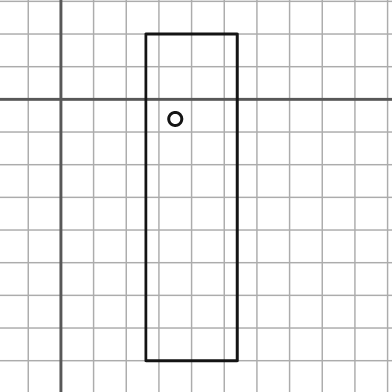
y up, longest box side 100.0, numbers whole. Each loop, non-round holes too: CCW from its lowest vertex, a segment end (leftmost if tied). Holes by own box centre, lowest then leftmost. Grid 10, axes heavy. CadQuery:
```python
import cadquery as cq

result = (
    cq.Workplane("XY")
    .moveTo(26.0, -80.0)
    .lineTo(54.0, -80.0)
    .lineTo(54.0, 20.0)
    .lineTo(26.0, 20.0)
    .close()
    .moveTo(35.0, -6.0)
    .circle(2.0)
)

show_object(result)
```